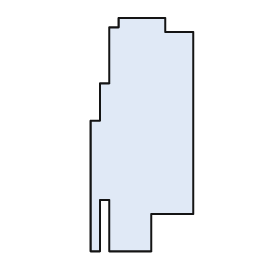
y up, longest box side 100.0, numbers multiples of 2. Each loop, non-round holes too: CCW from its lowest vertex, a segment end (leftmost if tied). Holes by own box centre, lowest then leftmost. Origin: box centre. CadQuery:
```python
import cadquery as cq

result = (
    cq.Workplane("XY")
    .moveTo(-22.0, -50.0)
    .lineTo(-18.0, -50.0)
    .lineTo(-18.0, -28.0)
    .lineTo(-14.0, -28.0)
    .lineTo(-14.0, -50.0)
    .lineTo(4.0, -50.0)
    .lineTo(4.0, -34.0)
    .lineTo(22.0, -34.0)
    .lineTo(22.0, 44.0)
    .lineTo(10.0, 44.0)
    .lineTo(10.0, 50.0)
    .lineTo(-10.0, 50.0)
    .lineTo(-10.0, 46.0)
    .lineTo(-14.0, 46.0)
    .lineTo(-14.0, 22.0)
    .lineTo(-18.0, 22.0)
    .lineTo(-18.0, 6.0)
    .lineTo(-22.0, 6.0)
    .close()
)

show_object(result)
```